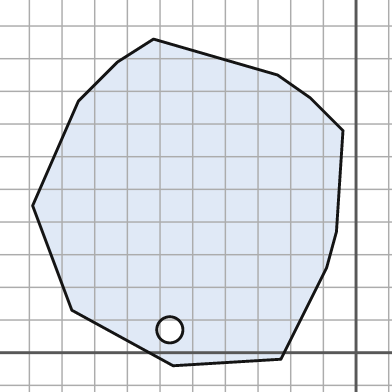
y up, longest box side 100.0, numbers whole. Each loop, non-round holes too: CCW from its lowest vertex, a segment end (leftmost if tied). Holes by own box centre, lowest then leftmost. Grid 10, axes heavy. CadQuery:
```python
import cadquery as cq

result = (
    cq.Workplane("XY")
    .moveTo(-56.0, -4.0)
    .lineTo(-23.0, -2.0)
    .lineTo(-9.0, 26.0)
    .lineTo(-6.0, 37.0)
    .lineTo(-4.0, 68.0)
    .lineTo(-14.0, 78.0)
    .lineTo(-24.0, 85.0)
    .lineTo(-62.0, 96.0)
    .lineTo(-73.0, 89.0)
    .lineTo(-85.0, 77.0)
    .lineTo(-99.0, 45.0)
    .lineTo(-87.0, 13.0)
    .close()
    .moveTo(-57.0, 7.0)
    .circle(4.0)
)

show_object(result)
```